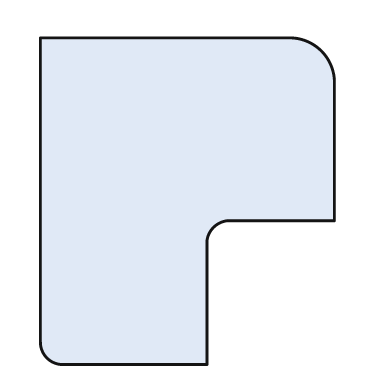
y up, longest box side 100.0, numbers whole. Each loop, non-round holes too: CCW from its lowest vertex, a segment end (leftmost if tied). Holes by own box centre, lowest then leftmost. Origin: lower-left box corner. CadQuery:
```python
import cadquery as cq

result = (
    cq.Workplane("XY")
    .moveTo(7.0, 0.0)
    .lineTo(51.0, 0.0)
    .lineTo(51.0, 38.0)
    .threePointArc((53.0, 42.0), (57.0, 44.0))
    .lineTo(90.0, 44.0)
    .lineTo(90.0, 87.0)
    .threePointArc((86.0, 96.0), (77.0, 100.0))
    .lineTo(0.0, 100.0)
    .lineTo(0.0, 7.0)
    .threePointArc((2.0, 2.0), (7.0, 0.0))
    .close()
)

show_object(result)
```